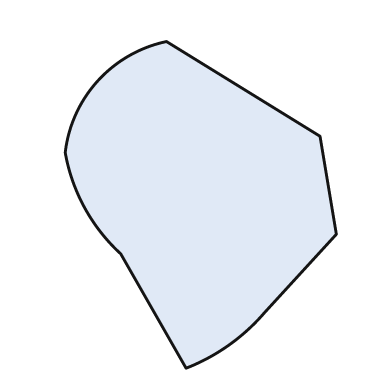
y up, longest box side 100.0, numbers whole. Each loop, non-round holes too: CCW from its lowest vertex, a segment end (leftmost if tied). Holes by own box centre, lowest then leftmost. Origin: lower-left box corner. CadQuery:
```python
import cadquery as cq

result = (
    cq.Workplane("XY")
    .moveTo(37.0, 0.0)
    .threePointArc((50.0, 7.0), (61.0, 17.0))
    .lineTo(83.0, 41.0)
    .lineTo(78.0, 71.0)
    .lineTo(31.0, 100.0)
    .threePointArc((10.0, 88.0), (0.0, 66.0))
    .threePointArc((6.0, 49.0), (17.0, 35.0))
    .close()
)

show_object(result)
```